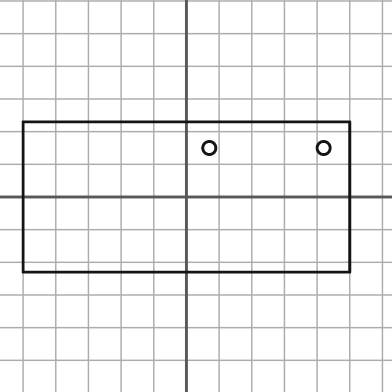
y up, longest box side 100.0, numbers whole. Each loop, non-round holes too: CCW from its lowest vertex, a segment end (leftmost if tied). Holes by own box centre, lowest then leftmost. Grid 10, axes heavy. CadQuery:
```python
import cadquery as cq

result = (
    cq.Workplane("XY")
    .moveTo(-50.0, -23.0)
    .lineTo(50.0, -23.0)
    .lineTo(50.0, 23.0)
    .lineTo(-50.0, 23.0)
    .close()
    .moveTo(7.0, 15.0)
    .circle(2.0)
    .moveTo(42.0, 15.0)
    .circle(2.0)
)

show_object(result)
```